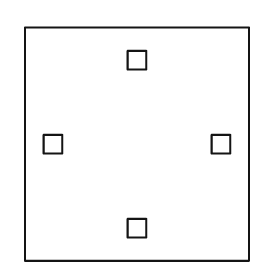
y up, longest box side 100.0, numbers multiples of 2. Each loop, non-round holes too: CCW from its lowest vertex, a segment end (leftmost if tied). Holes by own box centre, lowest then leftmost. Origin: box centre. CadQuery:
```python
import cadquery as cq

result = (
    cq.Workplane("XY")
    .moveTo(-48.0, -50.0)
    .lineTo(48.0, -50.0)
    .lineTo(48.0, 50.0)
    .lineTo(-48.0, 50.0)
    .close()
    .moveTo(-4.0, -40.0)
    .lineTo(4.0, -40.0)
    .lineTo(4.0, -32.0)
    .lineTo(-4.0, -32.0)
    .close()
    .moveTo(-40.0, -4.0)
    .lineTo(-32.0, -4.0)
    .lineTo(-32.0, 4.0)
    .lineTo(-40.0, 4.0)
    .close()
    .moveTo(32.0, -4.0)
    .lineTo(40.0, -4.0)
    .lineTo(40.0, 4.0)
    .lineTo(32.0, 4.0)
    .close()
    .moveTo(-4.0, 32.0)
    .lineTo(4.0, 32.0)
    .lineTo(4.0, 40.0)
    .lineTo(-4.0, 40.0)
    .close()
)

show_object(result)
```